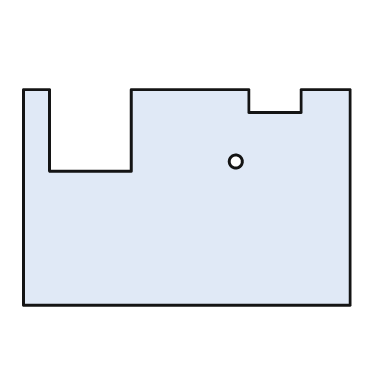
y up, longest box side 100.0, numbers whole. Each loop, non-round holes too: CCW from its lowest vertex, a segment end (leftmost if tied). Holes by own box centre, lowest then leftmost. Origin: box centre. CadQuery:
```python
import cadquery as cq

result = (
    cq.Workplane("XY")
    .moveTo(-50.0, -33.0)
    .lineTo(50.0, -33.0)
    .lineTo(50.0, 33.0)
    .lineTo(35.0, 33.0)
    .lineTo(35.0, 26.0)
    .lineTo(19.0, 26.0)
    .lineTo(19.0, 33.0)
    .lineTo(-17.0, 33.0)
    .lineTo(-17.0, 8.0)
    .lineTo(-42.0, 8.0)
    .lineTo(-42.0, 33.0)
    .lineTo(-50.0, 33.0)
    .close()
    .moveTo(15.0, 11.0)
    .circle(2.0)
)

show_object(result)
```